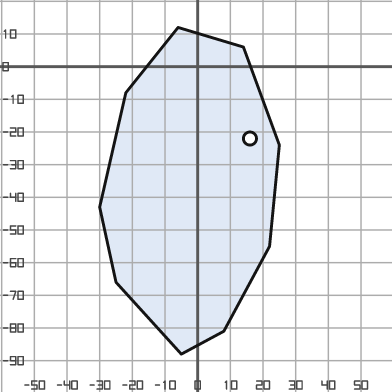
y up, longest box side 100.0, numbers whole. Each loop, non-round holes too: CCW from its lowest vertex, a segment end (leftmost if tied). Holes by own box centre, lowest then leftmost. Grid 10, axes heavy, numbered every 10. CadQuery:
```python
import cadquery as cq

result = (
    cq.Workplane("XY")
    .moveTo(-5.0, -88.0)
    .lineTo(8.0, -81.0)
    .lineTo(22.0, -55.0)
    .lineTo(25.0, -24.0)
    .lineTo(14.0, 6.0)
    .lineTo(-6.0, 12.0)
    .lineTo(-22.0, -8.0)
    .lineTo(-30.0, -43.0)
    .lineTo(-25.0, -66.0)
    .close()
    .moveTo(16.0, -22.0)
    .circle(2.0)
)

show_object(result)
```